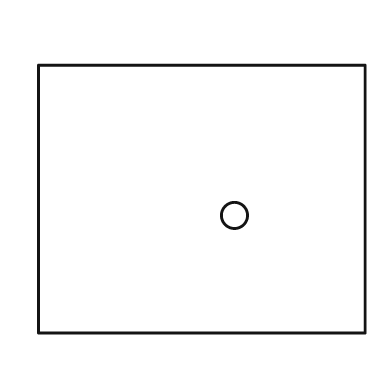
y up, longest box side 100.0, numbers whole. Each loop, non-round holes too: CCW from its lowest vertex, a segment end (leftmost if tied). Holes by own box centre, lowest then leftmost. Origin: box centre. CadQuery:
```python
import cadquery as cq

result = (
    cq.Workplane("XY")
    .moveTo(-50.0, -41.0)
    .lineTo(50.0, -41.0)
    .lineTo(50.0, 41.0)
    .lineTo(-50.0, 41.0)
    .close()
    .moveTo(10.0, -5.0)
    .circle(4.0)
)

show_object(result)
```